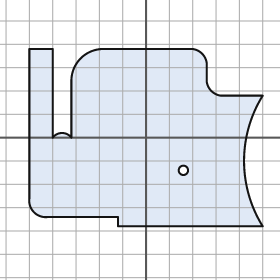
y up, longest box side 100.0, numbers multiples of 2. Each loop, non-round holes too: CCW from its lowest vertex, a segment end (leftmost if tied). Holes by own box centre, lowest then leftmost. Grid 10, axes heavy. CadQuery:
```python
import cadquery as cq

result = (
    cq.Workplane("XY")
    .moveTo(-12.0, -38.0)
    .lineTo(50.0, -38.0)
    .threePointArc((42.0, -10.0), (50.0, 18.0))
    .lineTo(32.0, 18.0)
    .threePointArc((28.0, 20.0), (26.0, 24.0))
    .lineTo(26.0, 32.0)
    .threePointArc((24.0, 36.0), (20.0, 38.0))
    .lineTo(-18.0, 38.0)
    .threePointArc((-28.0, 34.0), (-32.0, 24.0))
    .lineTo(-32.0, 0.0)
    .threePointArc((-36.0, 2.0), (-40.0, 0.0))
    .lineTo(-40.0, 38.0)
    .lineTo(-50.0, 38.0)
    .lineTo(-50.0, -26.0)
    .threePointArc((-48.0, -32.0), (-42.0, -34.0))
    .lineTo(-12.0, -34.0)
    .close()
    .moveTo(16.0, -14.0)
    .circle(2.0)
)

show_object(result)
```